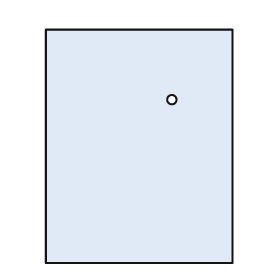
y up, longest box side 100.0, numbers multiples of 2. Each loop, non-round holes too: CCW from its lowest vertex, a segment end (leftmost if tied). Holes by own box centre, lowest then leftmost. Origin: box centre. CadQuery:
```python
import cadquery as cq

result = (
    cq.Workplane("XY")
    .moveTo(-40.0, -50.0)
    .lineTo(40.0, -50.0)
    .lineTo(40.0, 50.0)
    .lineTo(-40.0, 50.0)
    .close()
    .moveTo(14.0, 20.0)
    .circle(2.0)
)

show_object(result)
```